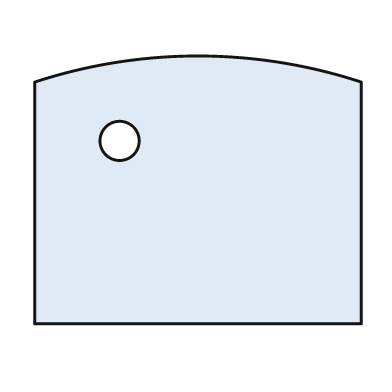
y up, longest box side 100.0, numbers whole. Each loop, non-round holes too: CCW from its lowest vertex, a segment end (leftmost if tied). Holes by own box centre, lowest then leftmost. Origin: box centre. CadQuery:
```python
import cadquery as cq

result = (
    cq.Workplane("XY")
    .moveTo(-50.0, -41.0)
    .lineTo(50.0, -41.0)
    .lineTo(50.0, 33.0)
    .threePointArc((0.0, 41.0), (-50.0, 33.0))
    .close()
    .moveTo(-24.0, 15.0)
    .circle(6.0)
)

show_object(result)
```